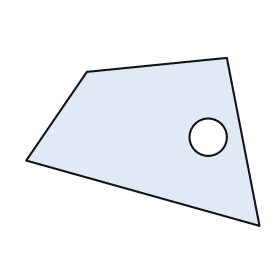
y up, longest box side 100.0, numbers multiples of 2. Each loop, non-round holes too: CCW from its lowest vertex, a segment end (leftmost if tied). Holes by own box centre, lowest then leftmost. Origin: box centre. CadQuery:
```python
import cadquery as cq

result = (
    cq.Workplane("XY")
    .moveTo(50.0, -36.0)
    .lineTo(36.0, 36.0)
    .lineTo(-24.0, 30.0)
    .lineTo(-50.0, -8.0)
    .close()
    .moveTo(28.0, 2.0)
    .circle(8.0)
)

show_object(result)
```